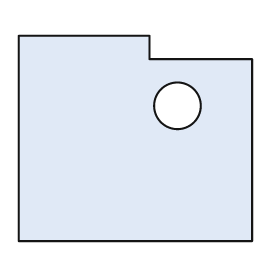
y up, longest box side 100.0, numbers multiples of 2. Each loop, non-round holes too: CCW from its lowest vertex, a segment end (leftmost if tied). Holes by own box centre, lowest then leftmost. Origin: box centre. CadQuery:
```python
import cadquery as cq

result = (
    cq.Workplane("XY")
    .moveTo(-50.0, -44.0)
    .lineTo(50.0, -44.0)
    .lineTo(50.0, 34.0)
    .lineTo(6.0, 34.0)
    .lineTo(6.0, 44.0)
    .lineTo(-50.0, 44.0)
    .close()
    .moveTo(18.0, 14.0)
    .circle(10.0)
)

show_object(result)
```